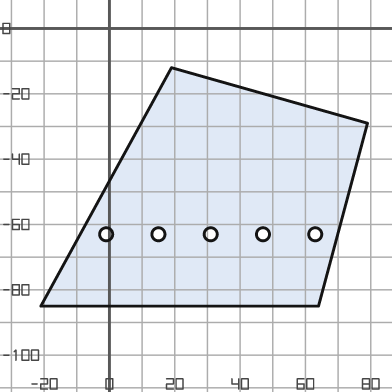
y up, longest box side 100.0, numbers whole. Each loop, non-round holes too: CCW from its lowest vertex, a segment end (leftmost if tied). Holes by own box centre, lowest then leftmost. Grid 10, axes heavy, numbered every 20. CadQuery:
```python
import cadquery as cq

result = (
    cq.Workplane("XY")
    .moveTo(-21.0, -85.0)
    .lineTo(64.0, -85.0)
    .lineTo(79.0, -29.0)
    .lineTo(19.0, -12.0)
    .close()
    .moveTo(-1.0, -63.0)
    .circle(2.0)
    .moveTo(15.0, -63.0)
    .circle(2.0)
    .moveTo(31.0, -63.0)
    .circle(2.0)
    .moveTo(47.0, -63.0)
    .circle(2.0)
    .moveTo(63.0, -63.0)
    .circle(2.0)
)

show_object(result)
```